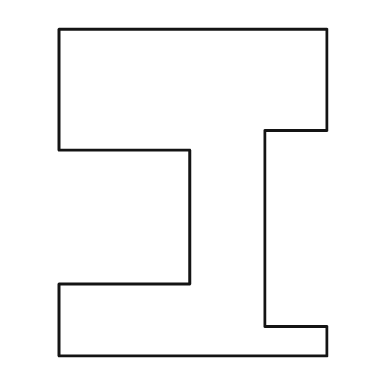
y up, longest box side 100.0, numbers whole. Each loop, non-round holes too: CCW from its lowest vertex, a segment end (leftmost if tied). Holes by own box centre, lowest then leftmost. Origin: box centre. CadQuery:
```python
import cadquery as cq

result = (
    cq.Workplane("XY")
    .moveTo(-41.0, -50.0)
    .lineTo(41.0, -50.0)
    .lineTo(41.0, -41.0)
    .lineTo(22.0, -41.0)
    .lineTo(22.0, 19.0)
    .lineTo(41.0, 19.0)
    .lineTo(41.0, 50.0)
    .lineTo(-41.0, 50.0)
    .lineTo(-41.0, 13.0)
    .lineTo(-1.0, 13.0)
    .lineTo(-1.0, -28.0)
    .lineTo(-41.0, -28.0)
    .close()
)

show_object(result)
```